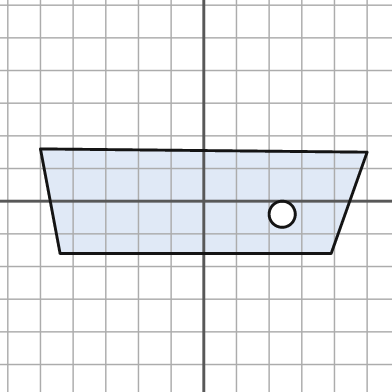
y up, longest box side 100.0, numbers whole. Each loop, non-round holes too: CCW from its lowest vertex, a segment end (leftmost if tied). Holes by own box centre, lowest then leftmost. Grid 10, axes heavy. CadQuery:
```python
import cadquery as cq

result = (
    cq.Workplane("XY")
    .moveTo(-44.0, -16.0)
    .lineTo(39.0, -16.0)
    .lineTo(50.0, 15.0)
    .lineTo(-50.0, 16.0)
    .close()
    .moveTo(24.0, -4.0)
    .circle(4.0)
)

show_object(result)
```